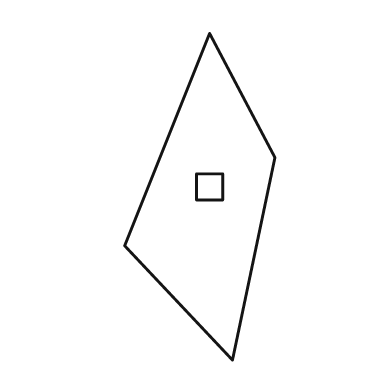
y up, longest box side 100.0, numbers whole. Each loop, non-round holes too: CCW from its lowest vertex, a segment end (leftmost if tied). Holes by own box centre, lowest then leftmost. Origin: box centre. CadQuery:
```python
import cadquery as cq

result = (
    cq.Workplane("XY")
    .moveTo(10.0, -50.0)
    .lineTo(23.0, 12.0)
    .lineTo(3.0, 50.0)
    .lineTo(-23.0, -15.0)
    .close()
    .moveTo(-1.0, -1.0)
    .lineTo(7.0, -1.0)
    .lineTo(7.0, 7.0)
    .lineTo(-1.0, 7.0)
    .close()
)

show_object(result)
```